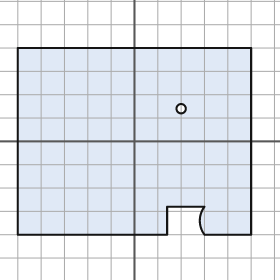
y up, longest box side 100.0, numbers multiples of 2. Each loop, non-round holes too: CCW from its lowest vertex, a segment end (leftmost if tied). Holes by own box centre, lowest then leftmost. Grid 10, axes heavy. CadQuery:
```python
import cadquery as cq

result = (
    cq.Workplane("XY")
    .moveTo(-50.0, -40.0)
    .lineTo(14.0, -40.0)
    .lineTo(14.0, -28.0)
    .lineTo(30.0, -28.0)
    .threePointArc((28.0, -34.0), (30.0, -40.0))
    .lineTo(50.0, -40.0)
    .lineTo(50.0, 40.0)
    .lineTo(-50.0, 40.0)
    .close()
    .moveTo(20.0, 14.0)
    .circle(2.0)
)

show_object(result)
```